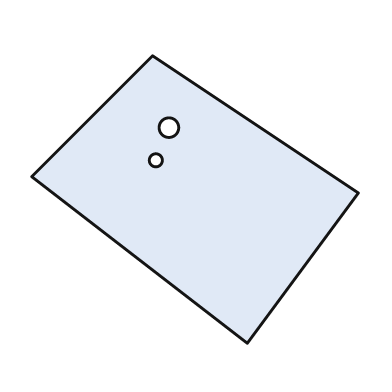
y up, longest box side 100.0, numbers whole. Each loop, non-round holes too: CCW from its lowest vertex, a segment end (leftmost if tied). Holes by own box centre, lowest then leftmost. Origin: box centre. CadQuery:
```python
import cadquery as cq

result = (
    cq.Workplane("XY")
    .moveTo(16.0, -44.0)
    .lineTo(50.0, 2.0)
    .lineTo(-13.0, 44.0)
    .lineTo(-50.0, 7.0)
    .close()
    .moveTo(-12.0, 12.0)
    .circle(2.0)
    .moveTo(-8.0, 22.0)
    .circle(3.0)
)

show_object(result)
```